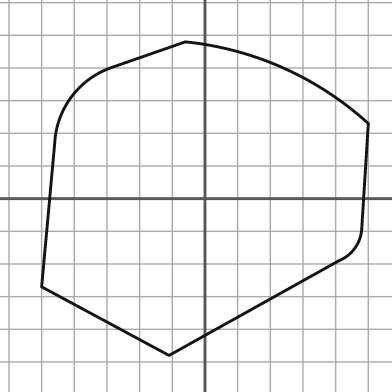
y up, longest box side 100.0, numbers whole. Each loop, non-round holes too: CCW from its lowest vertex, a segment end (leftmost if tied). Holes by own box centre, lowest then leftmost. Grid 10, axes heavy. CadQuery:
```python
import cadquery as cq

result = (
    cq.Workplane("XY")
    .moveTo(-11.0, -48.0)
    .lineTo(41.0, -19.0)
    .threePointArc((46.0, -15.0), (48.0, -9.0))
    .lineTo(50.0, 23.0)
    .threePointArc((24.0, 40.0), (-6.0, 48.0))
    .lineTo(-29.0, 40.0)
    .threePointArc((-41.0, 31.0), (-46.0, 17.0))
    .lineTo(-50.0, -27.0)
    .close()
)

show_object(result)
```